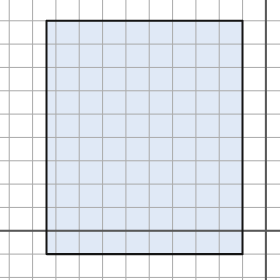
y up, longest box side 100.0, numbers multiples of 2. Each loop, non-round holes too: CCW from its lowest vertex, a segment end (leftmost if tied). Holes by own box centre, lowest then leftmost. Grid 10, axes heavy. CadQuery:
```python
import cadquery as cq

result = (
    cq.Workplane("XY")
    .moveTo(-94.0, -10.0)
    .lineTo(-10.0, -10.0)
    .lineTo(-10.0, 90.0)
    .lineTo(-94.0, 90.0)
    .close()
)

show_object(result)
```